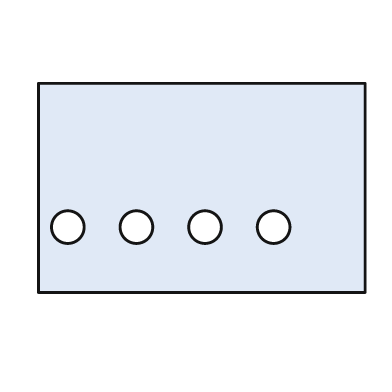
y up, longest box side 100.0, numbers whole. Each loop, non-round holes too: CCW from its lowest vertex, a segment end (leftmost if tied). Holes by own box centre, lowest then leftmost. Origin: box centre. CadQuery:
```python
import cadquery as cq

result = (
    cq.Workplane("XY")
    .moveTo(-50.0, -32.0)
    .lineTo(50.0, -32.0)
    .lineTo(50.0, 32.0)
    .lineTo(-50.0, 32.0)
    .close()
    .moveTo(-41.0, -12.0)
    .circle(5.0)
    .moveTo(-20.0, -12.0)
    .circle(5.0)
    .moveTo(1.0, -12.0)
    .circle(5.0)
    .moveTo(22.0, -12.0)
    .circle(5.0)
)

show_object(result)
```